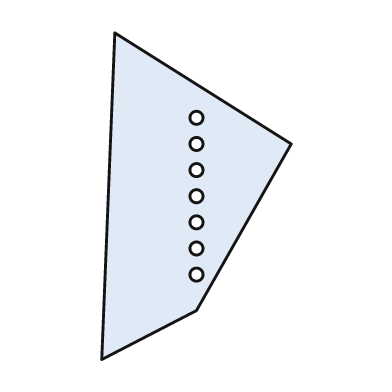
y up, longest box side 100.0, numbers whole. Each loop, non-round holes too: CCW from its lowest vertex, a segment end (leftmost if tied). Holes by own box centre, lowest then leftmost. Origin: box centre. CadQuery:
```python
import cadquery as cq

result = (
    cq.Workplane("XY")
    .moveTo(-29.0, -50.0)
    .lineTo(0.0, -35.0)
    .lineTo(29.0, 16.0)
    .lineTo(-25.0, 50.0)
    .close()
    .moveTo(0.0, -24.0)
    .circle(2.0)
    .moveTo(0.0, -16.0)
    .circle(2.0)
    .moveTo(0.0, -8.0)
    .circle(2.0)
    .moveTo(0.0, 0.0)
    .circle(2.0)
    .moveTo(0.0, 8.0)
    .circle(2.0)
    .moveTo(0.0, 16.0)
    .circle(2.0)
    .moveTo(0.0, 24.0)
    .circle(2.0)
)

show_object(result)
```